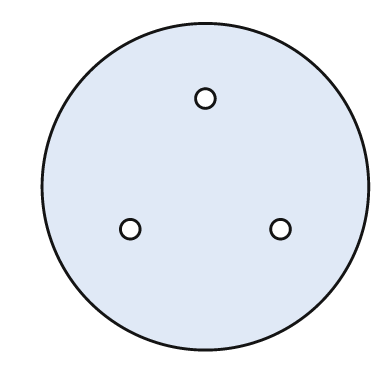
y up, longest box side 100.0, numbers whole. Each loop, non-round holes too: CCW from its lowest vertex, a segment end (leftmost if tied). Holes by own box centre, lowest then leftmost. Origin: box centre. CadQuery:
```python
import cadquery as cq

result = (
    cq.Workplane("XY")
    .moveTo(0.0, 0.0)
    .circle(50.0)
    .moveTo(-23.0, -13.0)
    .circle(3.0)
    .moveTo(23.0, -13.0)
    .circle(3.0)
    .moveTo(0.0, 27.0)
    .circle(3.0)
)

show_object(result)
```